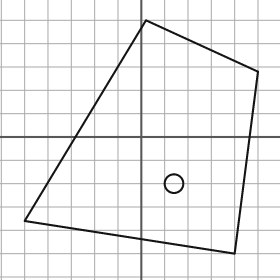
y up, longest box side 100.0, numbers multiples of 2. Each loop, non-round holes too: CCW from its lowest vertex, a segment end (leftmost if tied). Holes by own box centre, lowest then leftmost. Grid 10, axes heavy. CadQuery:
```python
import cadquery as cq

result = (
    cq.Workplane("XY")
    .moveTo(40.0, -50.0)
    .lineTo(50.0, 28.0)
    .lineTo(2.0, 50.0)
    .lineTo(-50.0, -36.0)
    .close()
    .moveTo(14.0, -20.0)
    .circle(4.0)
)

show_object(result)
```